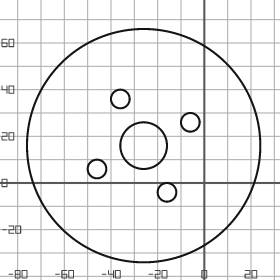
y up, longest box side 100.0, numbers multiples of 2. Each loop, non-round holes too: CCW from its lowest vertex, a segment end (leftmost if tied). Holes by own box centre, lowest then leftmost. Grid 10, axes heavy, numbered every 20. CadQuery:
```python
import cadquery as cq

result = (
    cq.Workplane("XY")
    .moveTo(-26.0, 16.0)
    .circle(50.0)
    .moveTo(-16.0, -4.0)
    .circle(4.0)
    .moveTo(-46.0, 6.0)
    .circle(4.0)
    .moveTo(-26.0, 16.0)
    .circle(10.0)
    .moveTo(-6.0, 26.0)
    .circle(4.0)
    .moveTo(-36.0, 36.0)
    .circle(4.0)
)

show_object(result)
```